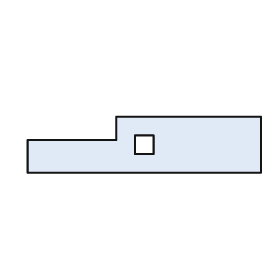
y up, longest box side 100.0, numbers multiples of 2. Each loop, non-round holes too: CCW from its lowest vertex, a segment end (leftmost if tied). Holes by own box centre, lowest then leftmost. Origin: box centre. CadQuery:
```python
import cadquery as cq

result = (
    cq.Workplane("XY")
    .moveTo(-50.0, -12.0)
    .lineTo(50.0, -12.0)
    .lineTo(50.0, 12.0)
    .lineTo(-12.0, 12.0)
    .lineTo(-12.0, 2.0)
    .lineTo(-50.0, 2.0)
    .close()
    .moveTo(-4.0, -4.0)
    .lineTo(4.0, -4.0)
    .lineTo(4.0, 4.0)
    .lineTo(-4.0, 4.0)
    .close()
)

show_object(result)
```